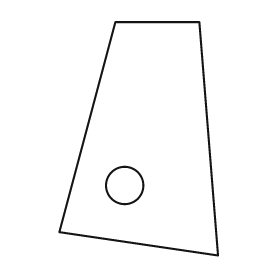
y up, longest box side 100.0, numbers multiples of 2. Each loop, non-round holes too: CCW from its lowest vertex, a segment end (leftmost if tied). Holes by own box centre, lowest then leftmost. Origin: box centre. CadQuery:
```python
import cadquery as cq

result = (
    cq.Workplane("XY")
    .moveTo(34.0, -50.0)
    .lineTo(26.0, 50.0)
    .lineTo(-10.0, 50.0)
    .lineTo(-34.0, -40.0)
    .close()
    .moveTo(-6.0, -20.0)
    .circle(8.0)
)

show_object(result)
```